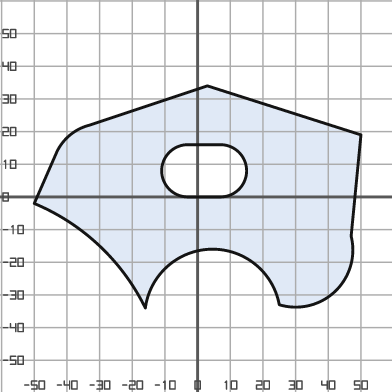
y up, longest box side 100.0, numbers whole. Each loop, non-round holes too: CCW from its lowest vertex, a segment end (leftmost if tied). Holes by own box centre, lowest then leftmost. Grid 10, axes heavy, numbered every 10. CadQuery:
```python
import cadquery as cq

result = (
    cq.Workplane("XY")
    .moveTo(-16.0, -34.0)
    .threePointArc((4.0, -16.0), (25.0, -33.0))
    .threePointArc((42.0, -29.0), (47.0, -12.0))
    .lineTo(50.0, 19.0)
    .lineTo(3.0, 34.0)
    .lineTo(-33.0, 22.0)
    .threePointArc((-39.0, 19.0), (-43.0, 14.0))
    .lineTo(-50.0, -2.0)
    .threePointArc((-30.0, -15.0), (-16.0, -34.0))
    .close()
    .moveTo(-3.0, 0.0)
    .lineTo(7.0, 0.0)
    .threePointArc((15.0, 8.0), (7.0, 16.0))
    .lineTo(-3.0, 16.0)
    .threePointArc((-11.0, 8.0), (-3.0, 0.0))
    .close()
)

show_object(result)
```